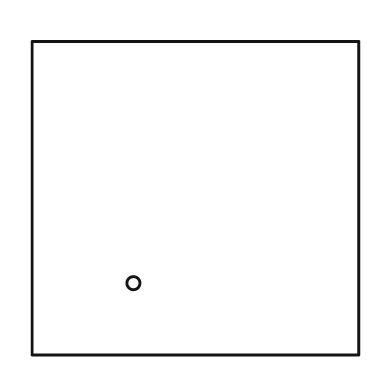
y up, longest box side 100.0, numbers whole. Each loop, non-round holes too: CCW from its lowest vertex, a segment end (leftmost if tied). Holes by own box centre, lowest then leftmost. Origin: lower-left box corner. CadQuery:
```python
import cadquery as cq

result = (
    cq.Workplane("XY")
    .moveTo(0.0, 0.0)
    .lineTo(100.0, 0.0)
    .lineTo(100.0, 96.0)
    .lineTo(0.0, 96.0)
    .close()
    .moveTo(31.0, 22.0)
    .circle(2.0)
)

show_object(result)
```